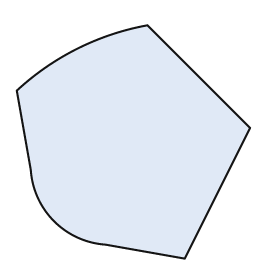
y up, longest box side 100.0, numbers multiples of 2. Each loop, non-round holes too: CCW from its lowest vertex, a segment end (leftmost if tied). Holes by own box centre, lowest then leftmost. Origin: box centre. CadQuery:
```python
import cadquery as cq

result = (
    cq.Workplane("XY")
    .moveTo(22.0, -50.0)
    .lineTo(50.0, 6.0)
    .lineTo(6.0, 50.0)
    .threePointArc((-24.0, 40.0), (-50.0, 22.0))
    .lineTo(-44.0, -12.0)
    .threePointArc((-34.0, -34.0), (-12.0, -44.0))
    .close()
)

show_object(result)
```